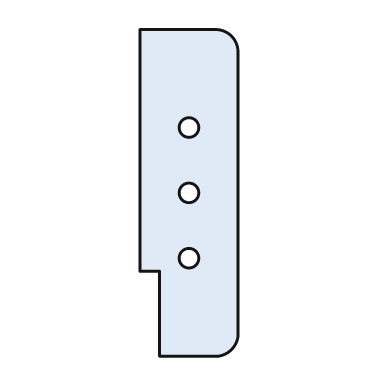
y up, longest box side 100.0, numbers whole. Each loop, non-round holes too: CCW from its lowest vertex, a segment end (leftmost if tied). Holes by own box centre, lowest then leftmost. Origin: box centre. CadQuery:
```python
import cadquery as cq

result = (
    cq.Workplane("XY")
    .moveTo(-9.0, -50.0)
    .lineTo(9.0, -50.0)
    .threePointArc((13.0, -48.0), (15.0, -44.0))
    .lineTo(15.0, 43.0)
    .threePointArc((13.0, 48.0), (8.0, 50.0))
    .lineTo(-15.0, 50.0)
    .lineTo(-15.0, -24.0)
    .lineTo(-9.0, -24.0)
    .close()
    .moveTo(0.0, -20.0)
    .circle(3.0)
    .moveTo(0.0, 0.0)
    .circle(3.0)
    .moveTo(0.0, 20.0)
    .circle(3.0)
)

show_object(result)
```